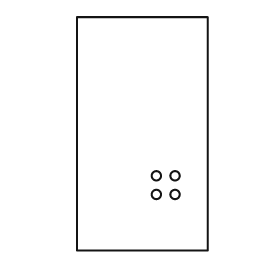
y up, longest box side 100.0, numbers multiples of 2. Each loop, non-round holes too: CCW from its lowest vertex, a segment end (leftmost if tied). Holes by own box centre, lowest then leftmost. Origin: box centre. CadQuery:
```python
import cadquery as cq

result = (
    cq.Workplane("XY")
    .moveTo(-28.0, -50.0)
    .lineTo(28.0, -50.0)
    .lineTo(28.0, 50.0)
    .lineTo(-28.0, 50.0)
    .close()
    .moveTo(6.0, -26.0)
    .circle(2.0)
    .moveTo(14.0, -26.0)
    .circle(2.0)
    .moveTo(6.0, -18.0)
    .circle(2.0)
    .moveTo(14.0, -18.0)
    .circle(2.0)
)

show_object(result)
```